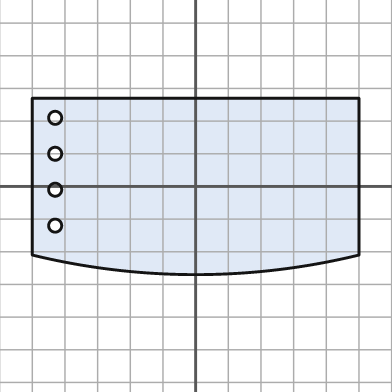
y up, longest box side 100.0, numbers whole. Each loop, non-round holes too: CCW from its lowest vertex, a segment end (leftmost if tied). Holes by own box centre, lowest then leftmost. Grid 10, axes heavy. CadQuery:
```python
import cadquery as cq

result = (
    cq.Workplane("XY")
    .moveTo(-50.0, -21.0)
    .threePointArc((0.0, -27.0), (50.0, -21.0))
    .lineTo(50.0, 27.0)
    .lineTo(-50.0, 27.0)
    .close()
    .moveTo(-43.0, -12.0)
    .circle(2.0)
    .moveTo(-43.0, -1.0)
    .circle(2.0)
    .moveTo(-43.0, 10.0)
    .circle(2.0)
    .moveTo(-43.0, 21.0)
    .circle(2.0)
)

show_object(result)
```